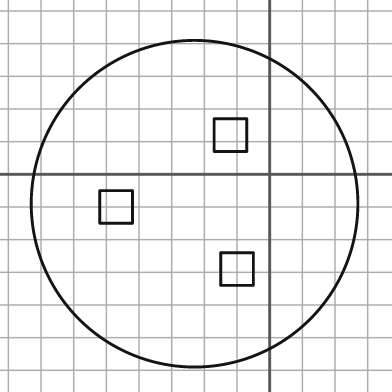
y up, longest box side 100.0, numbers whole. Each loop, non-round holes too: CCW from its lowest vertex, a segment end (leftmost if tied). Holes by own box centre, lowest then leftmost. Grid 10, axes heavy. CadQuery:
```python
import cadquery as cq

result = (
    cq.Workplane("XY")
    .moveTo(-23.0, -9.0)
    .circle(50.0)
    .moveTo(-15.0, -34.0)
    .lineTo(-5.0, -34.0)
    .lineTo(-5.0, -24.0)
    .lineTo(-15.0, -24.0)
    .close()
    .moveTo(-52.0, -15.0)
    .lineTo(-42.0, -15.0)
    .lineTo(-42.0, -5.0)
    .lineTo(-52.0, -5.0)
    .close()
    .moveTo(-17.0, 7.0)
    .lineTo(-7.0, 7.0)
    .lineTo(-7.0, 17.0)
    .lineTo(-17.0, 17.0)
    .close()
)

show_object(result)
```